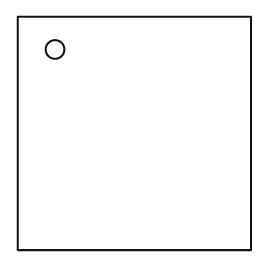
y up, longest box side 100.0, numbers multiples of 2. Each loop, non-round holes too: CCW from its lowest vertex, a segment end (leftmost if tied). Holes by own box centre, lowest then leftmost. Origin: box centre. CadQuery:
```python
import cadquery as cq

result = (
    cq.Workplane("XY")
    .moveTo(-50.0, -50.0)
    .lineTo(50.0, -50.0)
    .lineTo(50.0, 50.0)
    .lineTo(-50.0, 50.0)
    .close()
    .moveTo(-34.0, 36.0)
    .circle(4.0)
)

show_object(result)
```